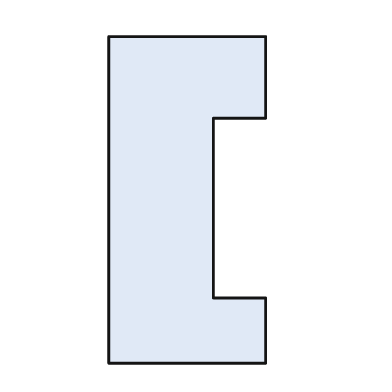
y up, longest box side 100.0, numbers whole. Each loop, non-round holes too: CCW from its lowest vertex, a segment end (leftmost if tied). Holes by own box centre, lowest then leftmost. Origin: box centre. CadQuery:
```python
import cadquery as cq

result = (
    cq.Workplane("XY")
    .moveTo(-24.0, -50.0)
    .lineTo(24.0, -50.0)
    .lineTo(24.0, -30.0)
    .lineTo(8.0, -30.0)
    .lineTo(8.0, 25.0)
    .lineTo(24.0, 25.0)
    .lineTo(24.0, 50.0)
    .lineTo(-24.0, 50.0)
    .close()
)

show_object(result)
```